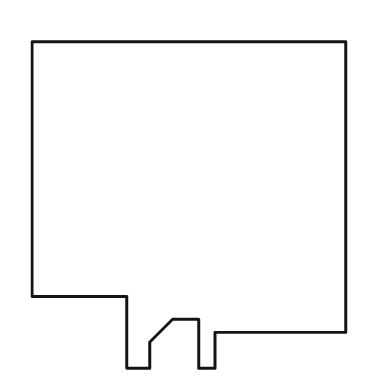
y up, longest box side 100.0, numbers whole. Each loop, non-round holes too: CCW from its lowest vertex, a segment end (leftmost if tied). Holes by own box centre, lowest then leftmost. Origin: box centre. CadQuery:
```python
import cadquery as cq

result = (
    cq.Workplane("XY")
    .moveTo(-19.0, -50.0)
    .lineTo(-12.0, -50.0)
    .lineTo(-12.0, -42.0)
    .lineTo(-5.0, -35.0)
    .lineTo(3.0, -35.0)
    .lineTo(3.0, -50.0)
    .lineTo(8.0, -50.0)
    .lineTo(8.0, -39.0)
    .lineTo(48.0, -39.0)
    .lineTo(48.0, 50.0)
    .lineTo(-48.0, 50.0)
    .lineTo(-48.0, -28.0)
    .lineTo(-19.0, -28.0)
    .close()
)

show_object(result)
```